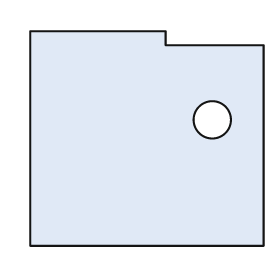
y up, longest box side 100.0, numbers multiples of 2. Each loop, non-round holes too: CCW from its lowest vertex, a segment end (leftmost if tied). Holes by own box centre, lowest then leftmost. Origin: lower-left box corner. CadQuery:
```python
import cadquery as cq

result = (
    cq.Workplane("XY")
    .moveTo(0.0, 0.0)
    .lineTo(100.0, 0.0)
    .lineTo(100.0, 86.0)
    .lineTo(58.0, 86.0)
    .lineTo(58.0, 92.0)
    .lineTo(0.0, 92.0)
    .close()
    .moveTo(78.0, 54.0)
    .circle(8.0)
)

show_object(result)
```